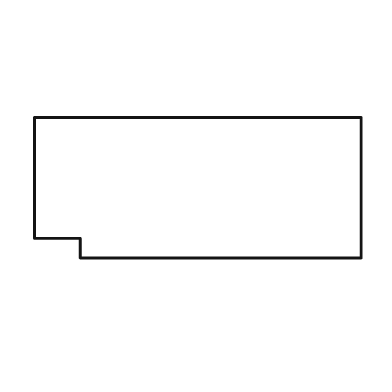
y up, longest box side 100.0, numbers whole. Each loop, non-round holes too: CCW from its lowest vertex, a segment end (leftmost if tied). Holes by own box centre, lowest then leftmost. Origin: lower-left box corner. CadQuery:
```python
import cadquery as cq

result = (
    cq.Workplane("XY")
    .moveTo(14.0, 0.0)
    .lineTo(100.0, 0.0)
    .lineTo(100.0, 43.0)
    .lineTo(0.0, 43.0)
    .lineTo(0.0, 6.0)
    .lineTo(14.0, 6.0)
    .close()
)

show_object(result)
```